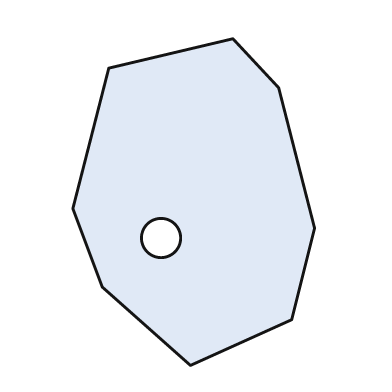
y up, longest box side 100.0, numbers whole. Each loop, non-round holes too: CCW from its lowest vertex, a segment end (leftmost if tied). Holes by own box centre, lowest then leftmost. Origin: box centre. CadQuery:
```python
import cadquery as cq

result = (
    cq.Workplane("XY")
    .moveTo(-1.0, -50.0)
    .lineTo(30.0, -36.0)
    .lineTo(37.0, -8.0)
    .lineTo(26.0, 35.0)
    .lineTo(12.0, 50.0)
    .lineTo(-26.0, 41.0)
    .lineTo(-37.0, -2.0)
    .lineTo(-28.0, -26.0)
    .close()
    .moveTo(-10.0, -11.0)
    .circle(6.0)
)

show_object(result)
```